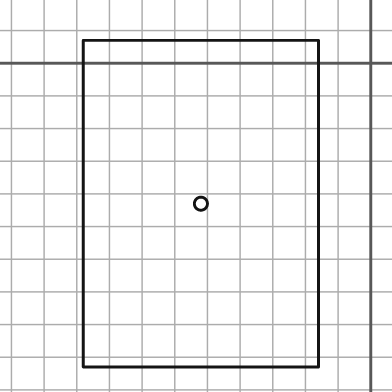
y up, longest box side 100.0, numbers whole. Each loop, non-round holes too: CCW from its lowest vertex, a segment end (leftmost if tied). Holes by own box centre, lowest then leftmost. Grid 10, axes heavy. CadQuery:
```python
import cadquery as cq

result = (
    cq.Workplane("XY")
    .moveTo(-88.0, -93.0)
    .lineTo(-16.0, -93.0)
    .lineTo(-16.0, 7.0)
    .lineTo(-88.0, 7.0)
    .close()
    .moveTo(-52.0, -43.0)
    .circle(2.0)
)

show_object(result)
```